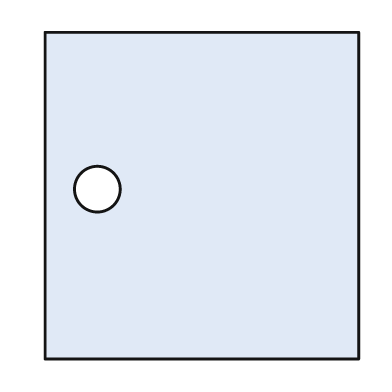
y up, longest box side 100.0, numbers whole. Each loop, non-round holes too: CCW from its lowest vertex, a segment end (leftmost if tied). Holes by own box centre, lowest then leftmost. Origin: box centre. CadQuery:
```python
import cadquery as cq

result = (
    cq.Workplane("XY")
    .moveTo(-48.0, -50.0)
    .lineTo(48.0, -50.0)
    .lineTo(48.0, 50.0)
    .lineTo(-48.0, 50.0)
    .close()
    .moveTo(-32.0, 2.0)
    .circle(7.0)
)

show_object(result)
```